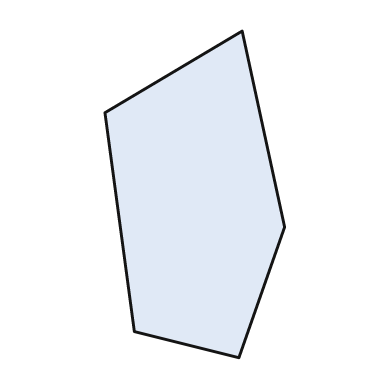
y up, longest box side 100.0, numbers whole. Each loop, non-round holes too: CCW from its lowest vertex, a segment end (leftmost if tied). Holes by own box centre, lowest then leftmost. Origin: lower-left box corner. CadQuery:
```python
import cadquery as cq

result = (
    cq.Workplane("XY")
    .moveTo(41.0, 0.0)
    .lineTo(55.0, 40.0)
    .lineTo(42.0, 100.0)
    .lineTo(0.0, 75.0)
    .lineTo(9.0, 8.0)
    .close()
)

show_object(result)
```